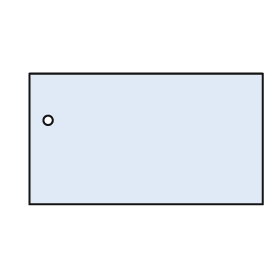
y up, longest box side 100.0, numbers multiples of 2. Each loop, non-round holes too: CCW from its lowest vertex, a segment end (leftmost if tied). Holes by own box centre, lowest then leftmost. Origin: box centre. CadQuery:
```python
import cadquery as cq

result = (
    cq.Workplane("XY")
    .moveTo(-50.0, -28.0)
    .lineTo(50.0, -28.0)
    .lineTo(50.0, 28.0)
    .lineTo(-50.0, 28.0)
    .close()
    .moveTo(-42.0, 8.0)
    .circle(2.0)
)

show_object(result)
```